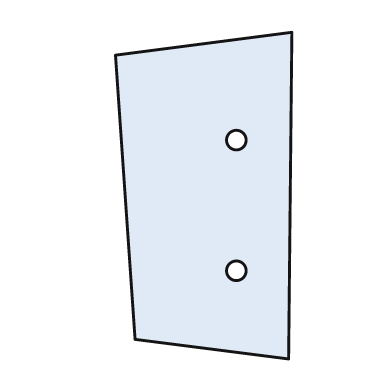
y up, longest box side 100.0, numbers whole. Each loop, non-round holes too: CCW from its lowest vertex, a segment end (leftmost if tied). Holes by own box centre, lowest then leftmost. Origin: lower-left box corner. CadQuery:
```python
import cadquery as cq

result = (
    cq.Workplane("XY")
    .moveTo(53.0, 0.0)
    .lineTo(54.0, 100.0)
    .lineTo(0.0, 93.0)
    .lineTo(6.0, 6.0)
    .close()
    .moveTo(37.0, 27.0)
    .circle(3.0)
    .moveTo(37.0, 67.0)
    .circle(3.0)
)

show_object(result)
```